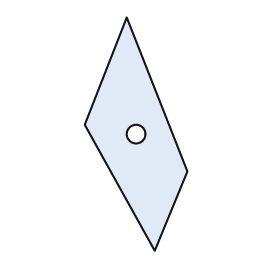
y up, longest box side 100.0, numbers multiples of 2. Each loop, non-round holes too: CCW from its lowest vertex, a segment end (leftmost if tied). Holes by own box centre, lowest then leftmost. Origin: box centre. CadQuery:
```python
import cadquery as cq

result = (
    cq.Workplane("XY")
    .moveTo(8.0, -50.0)
    .lineTo(22.0, -16.0)
    .lineTo(-4.0, 50.0)
    .lineTo(-22.0, 4.0)
    .close()
    .moveTo(0.0, 0.0)
    .circle(4.0)
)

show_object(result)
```